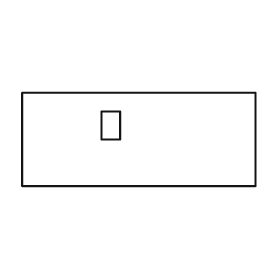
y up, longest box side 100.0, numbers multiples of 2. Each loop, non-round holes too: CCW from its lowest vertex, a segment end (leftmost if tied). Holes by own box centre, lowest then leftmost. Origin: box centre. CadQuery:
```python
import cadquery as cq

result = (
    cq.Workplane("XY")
    .moveTo(-50.0, -20.0)
    .lineTo(50.0, -20.0)
    .lineTo(50.0, 20.0)
    .lineTo(-50.0, 20.0)
    .close()
    .moveTo(-16.0, 0.0)
    .lineTo(-8.0, 0.0)
    .lineTo(-8.0, 12.0)
    .lineTo(-16.0, 12.0)
    .close()
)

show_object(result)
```